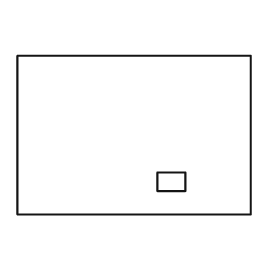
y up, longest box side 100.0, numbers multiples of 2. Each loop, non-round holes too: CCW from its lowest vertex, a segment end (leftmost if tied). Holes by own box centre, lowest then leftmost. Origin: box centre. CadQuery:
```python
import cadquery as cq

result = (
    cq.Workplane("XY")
    .moveTo(-50.0, -34.0)
    .lineTo(50.0, -34.0)
    .lineTo(50.0, 34.0)
    .lineTo(-50.0, 34.0)
    .close()
    .moveTo(10.0, -24.0)
    .lineTo(22.0, -24.0)
    .lineTo(22.0, -16.0)
    .lineTo(10.0, -16.0)
    .close()
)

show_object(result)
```